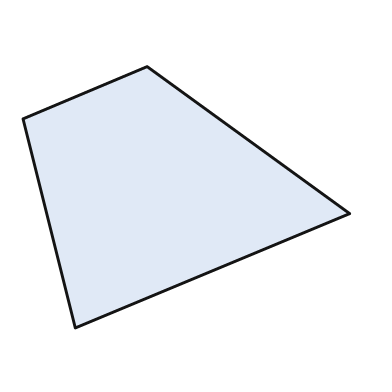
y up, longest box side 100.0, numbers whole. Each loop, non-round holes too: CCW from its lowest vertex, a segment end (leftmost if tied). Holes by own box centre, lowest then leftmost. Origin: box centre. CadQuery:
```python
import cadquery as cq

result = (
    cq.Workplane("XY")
    .moveTo(-34.0, -40.0)
    .lineTo(50.0, -5.0)
    .lineTo(-12.0, 40.0)
    .lineTo(-50.0, 24.0)
    .close()
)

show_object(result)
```